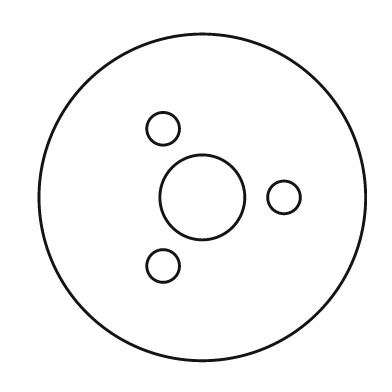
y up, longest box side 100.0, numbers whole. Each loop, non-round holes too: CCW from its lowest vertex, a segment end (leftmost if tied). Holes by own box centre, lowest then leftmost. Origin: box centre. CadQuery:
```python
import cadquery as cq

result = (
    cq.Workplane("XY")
    .moveTo(0.0, 0.0)
    .circle(50.0)
    .moveTo(-12.0, -21.0)
    .circle(5.0)
    .moveTo(0.0, 0.0)
    .circle(13.0)
    .moveTo(25.0, 0.0)
    .circle(5.0)
    .moveTo(-12.0, 21.0)
    .circle(5.0)
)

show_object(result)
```